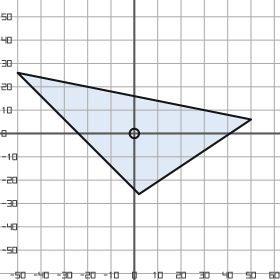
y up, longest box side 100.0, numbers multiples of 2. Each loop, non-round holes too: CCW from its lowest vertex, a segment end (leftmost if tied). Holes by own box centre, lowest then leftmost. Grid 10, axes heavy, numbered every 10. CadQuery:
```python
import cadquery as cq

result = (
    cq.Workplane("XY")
    .moveTo(2.0, -26.0)
    .lineTo(50.0, 6.0)
    .lineTo(-50.0, 26.0)
    .close()
    .moveTo(0.0, 0.0)
    .circle(2.0)
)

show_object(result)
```